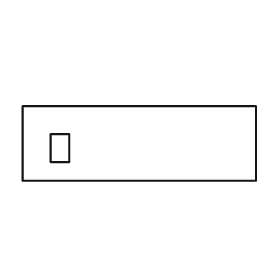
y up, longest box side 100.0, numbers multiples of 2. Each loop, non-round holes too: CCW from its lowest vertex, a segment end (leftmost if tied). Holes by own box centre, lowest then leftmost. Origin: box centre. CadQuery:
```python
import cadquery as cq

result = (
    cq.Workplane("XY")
    .moveTo(-50.0, -16.0)
    .lineTo(50.0, -16.0)
    .lineTo(50.0, 16.0)
    .lineTo(-50.0, 16.0)
    .close()
    .moveTo(-38.0, -8.0)
    .lineTo(-30.0, -8.0)
    .lineTo(-30.0, 4.0)
    .lineTo(-38.0, 4.0)
    .close()
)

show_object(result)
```